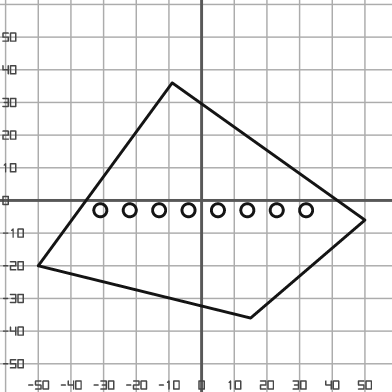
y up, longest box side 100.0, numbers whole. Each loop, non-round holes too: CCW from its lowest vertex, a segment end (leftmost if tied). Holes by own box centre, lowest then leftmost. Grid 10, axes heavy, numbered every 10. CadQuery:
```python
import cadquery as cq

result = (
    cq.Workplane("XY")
    .moveTo(15.0, -36.0)
    .lineTo(50.0, -6.0)
    .lineTo(-9.0, 36.0)
    .lineTo(-50.0, -20.0)
    .close()
    .moveTo(-31.0, -3.0)
    .circle(2.0)
    .moveTo(-22.0, -3.0)
    .circle(2.0)
    .moveTo(-13.0, -3.0)
    .circle(2.0)
    .moveTo(-4.0, -3.0)
    .circle(2.0)
    .moveTo(5.0, -3.0)
    .circle(2.0)
    .moveTo(14.0, -3.0)
    .circle(2.0)
    .moveTo(23.0, -3.0)
    .circle(2.0)
    .moveTo(32.0, -3.0)
    .circle(2.0)
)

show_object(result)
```